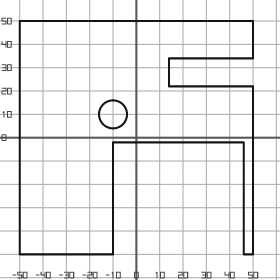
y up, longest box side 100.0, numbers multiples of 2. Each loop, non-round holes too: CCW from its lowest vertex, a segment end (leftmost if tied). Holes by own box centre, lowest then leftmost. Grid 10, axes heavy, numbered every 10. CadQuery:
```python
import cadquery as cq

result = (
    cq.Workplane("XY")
    .moveTo(-50.0, -50.0)
    .lineTo(-10.0, -50.0)
    .lineTo(-10.0, -2.0)
    .lineTo(46.0, -2.0)
    .lineTo(46.0, -50.0)
    .lineTo(50.0, -50.0)
    .lineTo(50.0, 22.0)
    .lineTo(14.0, 22.0)
    .lineTo(14.0, 34.0)
    .lineTo(50.0, 34.0)
    .lineTo(50.0, 50.0)
    .lineTo(-50.0, 50.0)
    .close()
    .moveTo(-10.0, 10.0)
    .circle(6.0)
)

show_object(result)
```